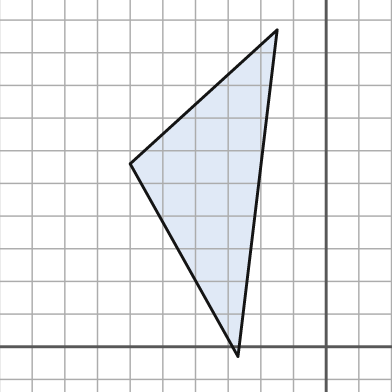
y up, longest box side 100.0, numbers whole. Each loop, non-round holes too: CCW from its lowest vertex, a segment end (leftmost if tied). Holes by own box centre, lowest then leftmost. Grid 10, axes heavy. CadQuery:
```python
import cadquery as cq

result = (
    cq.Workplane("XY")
    .moveTo(-27.0, -3.0)
    .lineTo(-15.0, 97.0)
    .lineTo(-60.0, 56.0)
    .close()
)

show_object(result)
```